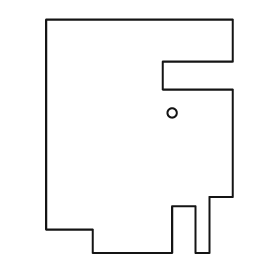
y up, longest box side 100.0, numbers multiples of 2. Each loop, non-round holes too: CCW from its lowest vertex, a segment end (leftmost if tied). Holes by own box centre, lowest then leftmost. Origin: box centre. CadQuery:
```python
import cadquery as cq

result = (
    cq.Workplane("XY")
    .moveTo(-20.0, -50.0)
    .lineTo(14.0, -50.0)
    .lineTo(14.0, -30.0)
    .lineTo(24.0, -30.0)
    .lineTo(24.0, -50.0)
    .lineTo(30.0, -50.0)
    .lineTo(30.0, -26.0)
    .lineTo(40.0, -26.0)
    .lineTo(40.0, 20.0)
    .lineTo(10.0, 20.0)
    .lineTo(10.0, 32.0)
    .lineTo(40.0, 32.0)
    .lineTo(40.0, 50.0)
    .lineTo(-40.0, 50.0)
    .lineTo(-40.0, -40.0)
    .lineTo(-20.0, -40.0)
    .close()
    .moveTo(14.0, 10.0)
    .circle(2.0)
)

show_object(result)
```